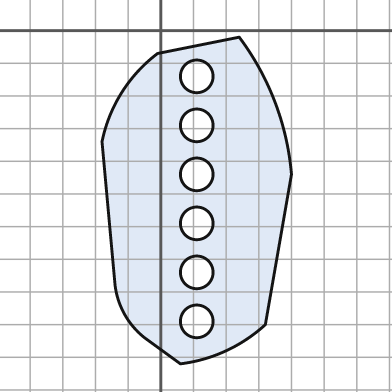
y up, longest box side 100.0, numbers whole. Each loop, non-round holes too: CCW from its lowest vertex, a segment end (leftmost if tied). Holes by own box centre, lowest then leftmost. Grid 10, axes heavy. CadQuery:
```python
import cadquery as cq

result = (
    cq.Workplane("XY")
    .moveTo(6.0, -102.0)
    .threePointArc((20.0, -98.0), (32.0, -90.0))
    .lineTo(40.0, -44.0)
    .threePointArc((35.0, -22.0), (24.0, -2.0))
    .lineTo(-1.0, -7.0)
    .threePointArc((-12.0, -19.0), (-18.0, -34.0))
    .lineTo(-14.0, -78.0)
    .threePointArc((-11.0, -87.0), (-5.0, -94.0))
    .close()
    .moveTo(11.0, -89.0)
    .circle(5.0)
    .moveTo(11.0, -74.0)
    .circle(5.0)
    .moveTo(11.0, -59.0)
    .circle(5.0)
    .moveTo(11.0, -44.0)
    .circle(5.0)
    .moveTo(11.0, -29.0)
    .circle(5.0)
    .moveTo(11.0, -14.0)
    .circle(5.0)
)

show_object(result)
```